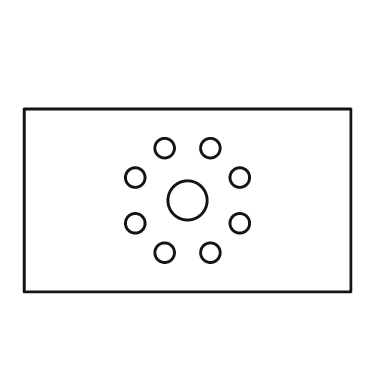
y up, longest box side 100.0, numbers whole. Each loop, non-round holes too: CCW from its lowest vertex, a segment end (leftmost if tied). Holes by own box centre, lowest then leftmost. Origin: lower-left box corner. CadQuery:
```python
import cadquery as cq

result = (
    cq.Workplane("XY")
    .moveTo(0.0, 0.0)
    .lineTo(100.0, 0.0)
    .lineTo(100.0, 56.0)
    .lineTo(0.0, 56.0)
    .close()
    .moveTo(43.0, 12.0)
    .circle(3.0)
    .moveTo(57.0, 12.0)
    .circle(3.0)
    .moveTo(34.0, 21.0)
    .circle(3.0)
    .moveTo(66.0, 21.0)
    .circle(3.0)
    .moveTo(50.0, 28.0)
    .circle(6.0)
    .moveTo(34.0, 35.0)
    .circle(3.0)
    .moveTo(66.0, 35.0)
    .circle(3.0)
    .moveTo(43.0, 44.0)
    .circle(3.0)
    .moveTo(57.0, 44.0)
    .circle(3.0)
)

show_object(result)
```